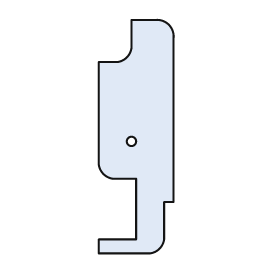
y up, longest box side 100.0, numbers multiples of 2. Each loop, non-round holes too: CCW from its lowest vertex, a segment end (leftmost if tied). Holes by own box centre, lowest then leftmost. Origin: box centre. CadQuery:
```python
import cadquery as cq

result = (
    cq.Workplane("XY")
    .moveTo(-16.0, -50.0)
    .lineTo(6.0, -50.0)
    .threePointArc((10.0, -48.0), (12.0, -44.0))
    .lineTo(12.0, -28.0)
    .lineTo(16.0, -28.0)
    .lineTo(16.0, 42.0)
    .threePointArc((14.0, 48.0), (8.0, 50.0))
    .lineTo(-2.0, 50.0)
    .lineTo(-2.0, 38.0)
    .threePointArc((-4.0, 34.0), (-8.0, 32.0))
    .lineTo(-16.0, 32.0)
    .lineTo(-16.0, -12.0)
    .threePointArc((-14.0, -16.0), (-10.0, -18.0))
    .lineTo(0.0, -18.0)
    .lineTo(0.0, -44.0)
    .lineTo(-16.0, -44.0)
    .close()
    .moveTo(-2.0, -2.0)
    .circle(2.0)
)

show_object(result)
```